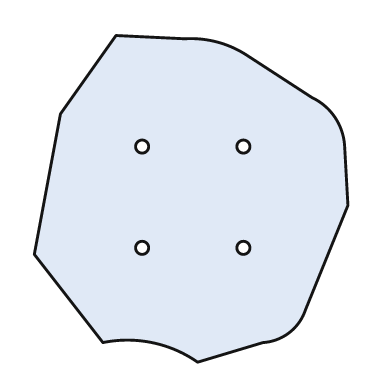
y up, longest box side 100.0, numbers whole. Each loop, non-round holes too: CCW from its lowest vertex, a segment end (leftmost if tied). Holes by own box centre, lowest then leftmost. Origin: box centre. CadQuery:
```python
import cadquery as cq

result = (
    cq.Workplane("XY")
    .moveTo(2.0, -50.0)
    .lineTo(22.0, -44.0)
    .threePointArc((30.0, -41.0), (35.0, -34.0))
    .lineTo(48.0, -2.0)
    .lineTo(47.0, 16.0)
    .threePointArc((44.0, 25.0), (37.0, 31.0))
    .lineTo(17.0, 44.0)
    .threePointArc((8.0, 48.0), (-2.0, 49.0))
    .lineTo(-23.0, 50.0)
    .lineTo(-40.0, 26.0)
    .lineTo(-48.0, -17.0)
    .lineTo(-27.0, -44.0)
    .threePointArc((-12.0, -44.0), (2.0, -50.0))
    .close()
    .moveTo(-15.0, -15.0)
    .circle(2.0)
    .moveTo(16.0, -15.0)
    .circle(2.0)
    .moveTo(-15.0, 16.0)
    .circle(2.0)
    .moveTo(16.0, 16.0)
    .circle(2.0)
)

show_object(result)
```